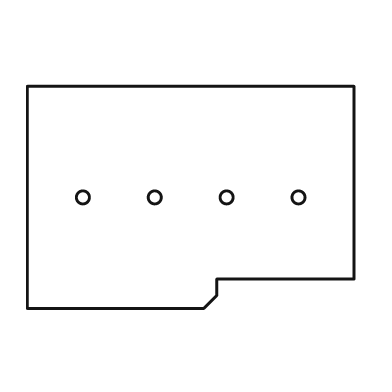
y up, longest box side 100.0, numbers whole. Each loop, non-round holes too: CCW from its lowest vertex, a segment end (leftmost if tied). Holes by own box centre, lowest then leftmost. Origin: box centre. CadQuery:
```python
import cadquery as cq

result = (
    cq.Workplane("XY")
    .moveTo(-50.0, -34.0)
    .lineTo(4.0, -34.0)
    .lineTo(8.0, -30.0)
    .lineTo(8.0, -25.0)
    .lineTo(50.0, -25.0)
    .lineTo(50.0, 34.0)
    .lineTo(-50.0, 34.0)
    .close()
    .moveTo(-33.0, 0.0)
    .circle(2.0)
    .moveTo(-11.0, 0.0)
    .circle(2.0)
    .moveTo(11.0, 0.0)
    .circle(2.0)
    .moveTo(33.0, 0.0)
    .circle(2.0)
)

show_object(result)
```